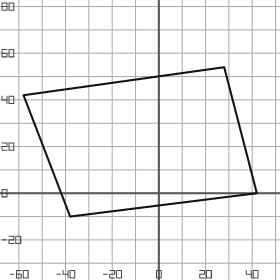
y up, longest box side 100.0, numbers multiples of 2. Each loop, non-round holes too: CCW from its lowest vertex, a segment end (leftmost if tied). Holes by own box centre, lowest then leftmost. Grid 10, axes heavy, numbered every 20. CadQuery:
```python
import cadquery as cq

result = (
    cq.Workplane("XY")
    .moveTo(-38.0, -10.0)
    .lineTo(42.0, 0.0)
    .lineTo(28.0, 54.0)
    .lineTo(-58.0, 42.0)
    .close()
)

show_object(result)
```